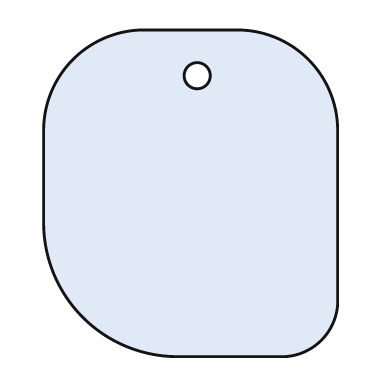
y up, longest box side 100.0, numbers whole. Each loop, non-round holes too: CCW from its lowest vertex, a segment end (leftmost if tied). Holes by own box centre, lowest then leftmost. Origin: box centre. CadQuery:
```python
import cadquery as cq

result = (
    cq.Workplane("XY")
    .moveTo(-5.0, -50.0)
    .lineTo(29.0, -50.0)
    .threePointArc((40.0, -45.0), (45.0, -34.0))
    .lineTo(45.0, 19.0)
    .threePointArc((36.0, 41.0), (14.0, 50.0))
    .lineTo(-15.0, 50.0)
    .threePointArc((-36.0, 41.0), (-45.0, 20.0))
    .lineTo(-45.0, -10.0)
    .threePointArc((-33.0, -38.0), (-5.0, -50.0))
    .close()
    .moveTo(2.0, 36.0)
    .circle(4.0)
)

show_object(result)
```